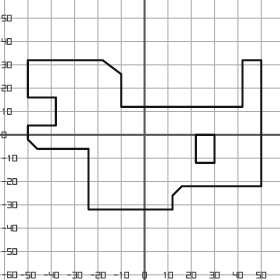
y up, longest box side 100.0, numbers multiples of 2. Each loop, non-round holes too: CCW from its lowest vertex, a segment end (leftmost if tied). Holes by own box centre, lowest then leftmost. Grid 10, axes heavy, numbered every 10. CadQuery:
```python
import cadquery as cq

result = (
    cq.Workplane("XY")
    .moveTo(-24.0, -32.0)
    .lineTo(12.0, -32.0)
    .lineTo(12.0, -26.0)
    .lineTo(16.0, -22.0)
    .lineTo(50.0, -22.0)
    .lineTo(50.0, 32.0)
    .lineTo(42.0, 32.0)
    .lineTo(42.0, 12.0)
    .lineTo(-10.0, 12.0)
    .lineTo(-10.0, 26.0)
    .lineTo(-18.0, 32.0)
    .lineTo(-50.0, 32.0)
    .lineTo(-50.0, 16.0)
    .lineTo(-38.0, 16.0)
    .lineTo(-38.0, 4.0)
    .lineTo(-50.0, 4.0)
    .lineTo(-50.0, -2.0)
    .lineTo(-46.0, -6.0)
    .lineTo(-24.0, -6.0)
    .close()
    .moveTo(22.0, -12.0)
    .lineTo(30.0, -12.0)
    .lineTo(30.0, 0.0)
    .lineTo(22.0, 0.0)
    .close()
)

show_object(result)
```